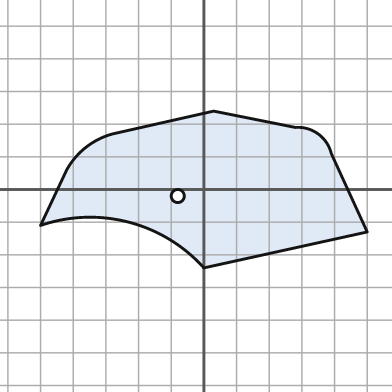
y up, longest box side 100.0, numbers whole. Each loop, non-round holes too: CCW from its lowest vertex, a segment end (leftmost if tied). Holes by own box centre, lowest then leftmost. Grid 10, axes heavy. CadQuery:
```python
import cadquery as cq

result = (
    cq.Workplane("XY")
    .moveTo(0.0, -24.0)
    .lineTo(50.0, -13.0)
    .lineTo(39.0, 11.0)
    .threePointArc((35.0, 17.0), (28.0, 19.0))
    .lineTo(3.0, 24.0)
    .lineTo(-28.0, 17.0)
    .threePointArc((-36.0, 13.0), (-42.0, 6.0))
    .lineTo(-50.0, -11.0)
    .threePointArc((-23.0, -10.0), (0.0, -24.0))
    .close()
    .moveTo(-8.0, -2.0)
    .circle(2.0)
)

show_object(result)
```